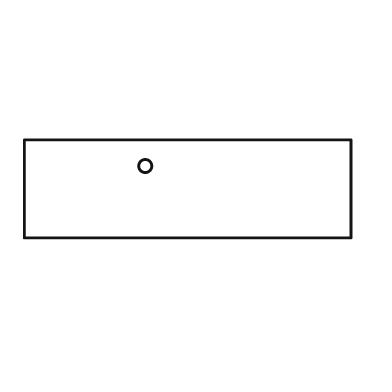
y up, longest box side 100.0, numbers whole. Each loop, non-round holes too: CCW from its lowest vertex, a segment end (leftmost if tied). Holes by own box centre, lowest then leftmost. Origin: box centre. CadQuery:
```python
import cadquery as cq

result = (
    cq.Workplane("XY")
    .moveTo(-50.0, -15.0)
    .lineTo(50.0, -15.0)
    .lineTo(50.0, 15.0)
    .lineTo(-50.0, 15.0)
    .close()
    .moveTo(-13.0, 7.0)
    .circle(2.0)
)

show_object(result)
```